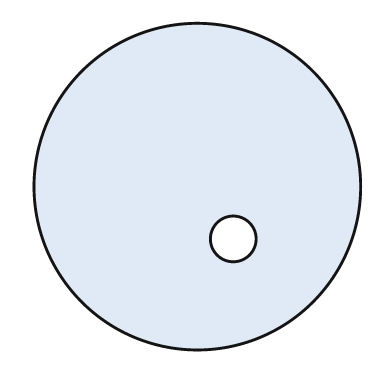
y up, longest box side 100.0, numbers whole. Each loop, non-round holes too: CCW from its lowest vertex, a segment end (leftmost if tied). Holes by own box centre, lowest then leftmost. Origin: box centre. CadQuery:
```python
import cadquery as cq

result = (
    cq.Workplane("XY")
    .moveTo(0.0, 0.0)
    .circle(50.0)
    .moveTo(11.0, -16.0)
    .circle(7.0)
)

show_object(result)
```